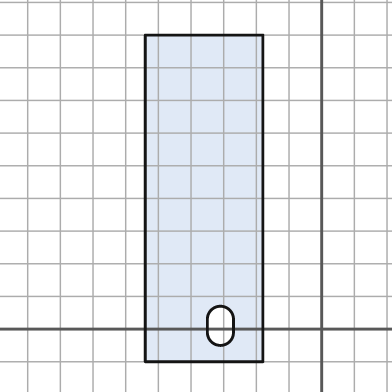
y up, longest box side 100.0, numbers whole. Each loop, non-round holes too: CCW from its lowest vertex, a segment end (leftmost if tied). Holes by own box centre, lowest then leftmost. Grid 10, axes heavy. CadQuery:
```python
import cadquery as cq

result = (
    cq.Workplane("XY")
    .moveTo(-54.0, -10.0)
    .lineTo(-18.0, -10.0)
    .lineTo(-18.0, 90.0)
    .lineTo(-54.0, 90.0)
    .close()
    .moveTo(-35.0, -1.0)
    .threePointArc((-31.0, -5.0), (-27.0, -1.0))
    .lineTo(-27.0, 3.0)
    .threePointArc((-31.0, 7.0), (-35.0, 3.0))
    .close()
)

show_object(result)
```